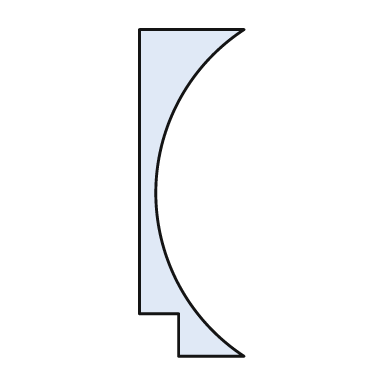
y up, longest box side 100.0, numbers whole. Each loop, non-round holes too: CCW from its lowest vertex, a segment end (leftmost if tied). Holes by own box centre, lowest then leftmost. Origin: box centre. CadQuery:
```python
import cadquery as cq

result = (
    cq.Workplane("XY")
    .moveTo(-4.0, -50.0)
    .lineTo(16.0, -50.0)
    .threePointArc((-11.0, 0.0), (16.0, 50.0))
    .lineTo(-16.0, 50.0)
    .lineTo(-16.0, -37.0)
    .lineTo(-4.0, -37.0)
    .close()
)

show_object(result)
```